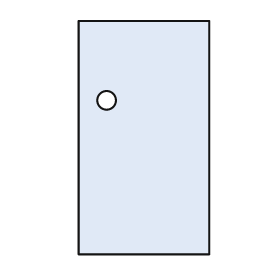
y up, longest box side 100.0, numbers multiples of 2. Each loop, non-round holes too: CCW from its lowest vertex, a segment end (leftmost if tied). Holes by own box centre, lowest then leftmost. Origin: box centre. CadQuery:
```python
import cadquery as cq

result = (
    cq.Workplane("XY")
    .moveTo(-28.0, -50.0)
    .lineTo(28.0, -50.0)
    .lineTo(28.0, 50.0)
    .lineTo(-28.0, 50.0)
    .close()
    .moveTo(-16.0, 16.0)
    .circle(4.0)
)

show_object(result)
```